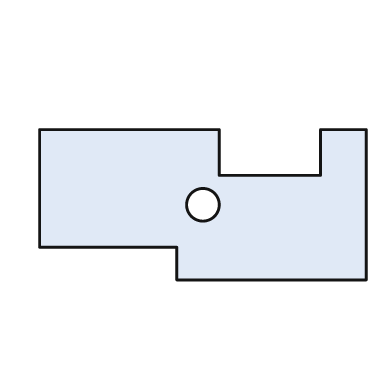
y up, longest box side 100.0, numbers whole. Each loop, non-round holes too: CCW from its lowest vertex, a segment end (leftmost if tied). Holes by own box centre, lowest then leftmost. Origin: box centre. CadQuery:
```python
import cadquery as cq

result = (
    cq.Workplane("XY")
    .moveTo(-8.0, -23.0)
    .lineTo(50.0, -23.0)
    .lineTo(50.0, 23.0)
    .lineTo(36.0, 23.0)
    .lineTo(36.0, 9.0)
    .lineTo(5.0, 9.0)
    .lineTo(5.0, 23.0)
    .lineTo(-50.0, 23.0)
    .lineTo(-50.0, -13.0)
    .lineTo(-8.0, -13.0)
    .close()
    .moveTo(0.0, 0.0)
    .circle(5.0)
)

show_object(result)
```